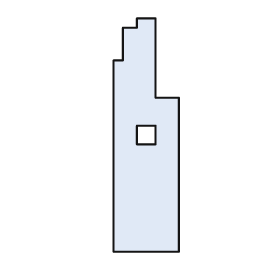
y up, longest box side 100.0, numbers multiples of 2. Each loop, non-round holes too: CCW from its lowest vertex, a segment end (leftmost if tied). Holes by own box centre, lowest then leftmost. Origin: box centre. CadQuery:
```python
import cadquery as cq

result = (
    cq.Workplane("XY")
    .moveTo(-14.0, -50.0)
    .lineTo(14.0, -50.0)
    .lineTo(14.0, 16.0)
    .lineTo(4.0, 16.0)
    .lineTo(4.0, 50.0)
    .lineTo(-4.0, 50.0)
    .lineTo(-4.0, 46.0)
    .lineTo(-10.0, 46.0)
    .lineTo(-10.0, 32.0)
    .lineTo(-14.0, 32.0)
    .close()
    .moveTo(-4.0, -4.0)
    .lineTo(4.0, -4.0)
    .lineTo(4.0, 4.0)
    .lineTo(-4.0, 4.0)
    .close()
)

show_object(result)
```